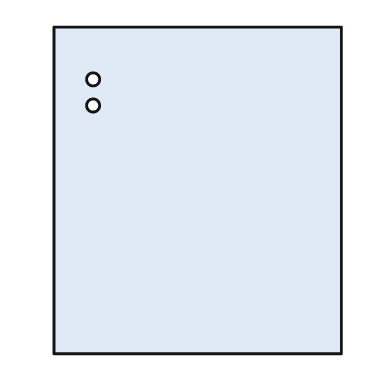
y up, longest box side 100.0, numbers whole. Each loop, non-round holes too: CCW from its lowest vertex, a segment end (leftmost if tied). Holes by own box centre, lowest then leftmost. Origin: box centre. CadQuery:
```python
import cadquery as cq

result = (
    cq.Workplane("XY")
    .moveTo(-44.0, -50.0)
    .lineTo(44.0, -50.0)
    .lineTo(44.0, 50.0)
    .lineTo(-44.0, 50.0)
    .close()
    .moveTo(-32.0, 26.0)
    .circle(2.0)
    .moveTo(-32.0, 34.0)
    .circle(2.0)
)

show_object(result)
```